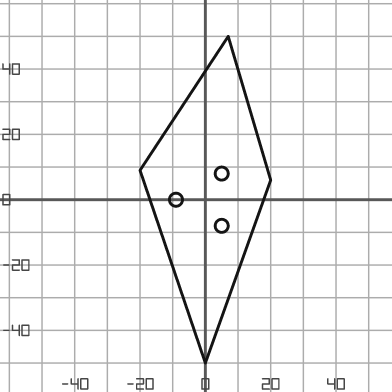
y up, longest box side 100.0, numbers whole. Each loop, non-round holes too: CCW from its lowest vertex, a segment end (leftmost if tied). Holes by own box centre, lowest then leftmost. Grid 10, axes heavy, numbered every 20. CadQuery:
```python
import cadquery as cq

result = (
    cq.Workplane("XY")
    .moveTo(0.0, -50.0)
    .lineTo(20.0, 6.0)
    .lineTo(7.0, 50.0)
    .lineTo(-20.0, 9.0)
    .close()
    .moveTo(5.0, -8.0)
    .circle(2.0)
    .moveTo(-9.0, 0.0)
    .circle(2.0)
    .moveTo(5.0, 8.0)
    .circle(2.0)
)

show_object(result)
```